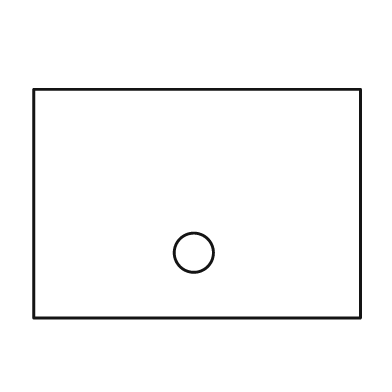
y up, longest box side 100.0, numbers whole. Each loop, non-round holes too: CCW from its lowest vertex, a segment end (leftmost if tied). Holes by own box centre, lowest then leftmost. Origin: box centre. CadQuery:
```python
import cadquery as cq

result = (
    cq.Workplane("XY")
    .moveTo(-50.0, -35.0)
    .lineTo(50.0, -35.0)
    .lineTo(50.0, 35.0)
    .lineTo(-50.0, 35.0)
    .close()
    .moveTo(-1.0, -15.0)
    .circle(6.0)
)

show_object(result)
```